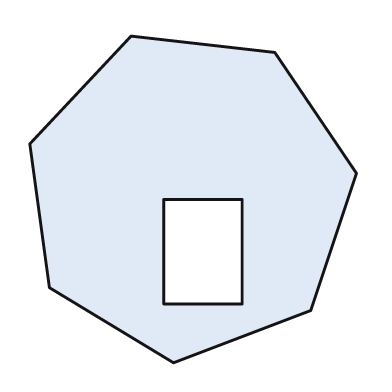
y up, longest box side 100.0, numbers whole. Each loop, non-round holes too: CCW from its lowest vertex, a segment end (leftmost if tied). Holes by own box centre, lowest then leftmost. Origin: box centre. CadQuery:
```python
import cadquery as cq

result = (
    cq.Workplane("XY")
    .moveTo(-6.0, -50.0)
    .lineTo(36.0, -34.0)
    .lineTo(50.0, 8.0)
    .lineTo(25.0, 45.0)
    .lineTo(-19.0, 50.0)
    .lineTo(-50.0, 17.0)
    .lineTo(-44.0, -27.0)
    .close()
    .moveTo(-9.0, -32.0)
    .lineTo(15.0, -32.0)
    .lineTo(15.0, 0.0)
    .lineTo(-9.0, 0.0)
    .close()
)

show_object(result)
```